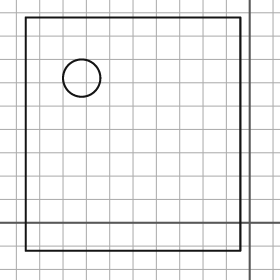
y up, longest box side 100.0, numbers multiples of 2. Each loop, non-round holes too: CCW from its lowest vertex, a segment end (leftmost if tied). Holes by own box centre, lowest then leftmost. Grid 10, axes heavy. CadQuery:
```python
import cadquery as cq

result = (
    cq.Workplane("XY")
    .moveTo(-96.0, -12.0)
    .lineTo(-4.0, -12.0)
    .lineTo(-4.0, 88.0)
    .lineTo(-96.0, 88.0)
    .close()
    .moveTo(-72.0, 62.0)
    .circle(8.0)
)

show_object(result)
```